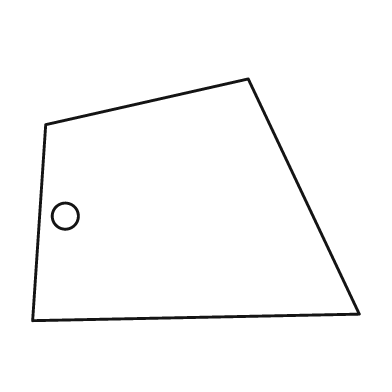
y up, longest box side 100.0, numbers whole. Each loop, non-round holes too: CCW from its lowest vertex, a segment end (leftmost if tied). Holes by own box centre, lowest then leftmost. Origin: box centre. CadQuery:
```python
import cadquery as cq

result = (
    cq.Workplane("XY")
    .moveTo(-50.0, -37.0)
    .lineTo(50.0, -35.0)
    .lineTo(16.0, 37.0)
    .lineTo(-46.0, 23.0)
    .close()
    .moveTo(-40.0, -5.0)
    .circle(4.0)
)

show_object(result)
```